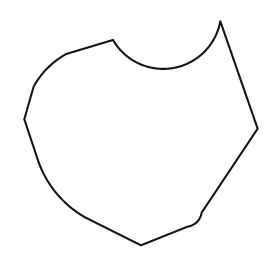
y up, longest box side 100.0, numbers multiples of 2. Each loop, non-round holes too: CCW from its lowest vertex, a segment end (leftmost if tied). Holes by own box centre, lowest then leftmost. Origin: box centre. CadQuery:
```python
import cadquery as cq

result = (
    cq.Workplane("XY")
    .moveTo(0.0, -48.0)
    .lineTo(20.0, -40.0)
    .threePointArc((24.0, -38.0), (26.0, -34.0))
    .lineTo(50.0, 2.0)
    .lineTo(34.0, 48.0)
    .threePointArc((14.0, 28.0), (-12.0, 40.0))
    .lineTo(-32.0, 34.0)
    .threePointArc((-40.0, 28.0), (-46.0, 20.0))
    .lineTo(-50.0, 6.0)
    .lineTo(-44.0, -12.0)
    .threePointArc((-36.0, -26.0), (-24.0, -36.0))
    .close()
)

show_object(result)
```